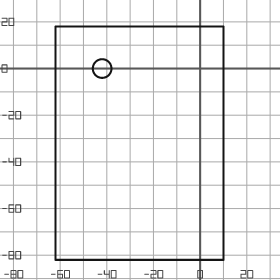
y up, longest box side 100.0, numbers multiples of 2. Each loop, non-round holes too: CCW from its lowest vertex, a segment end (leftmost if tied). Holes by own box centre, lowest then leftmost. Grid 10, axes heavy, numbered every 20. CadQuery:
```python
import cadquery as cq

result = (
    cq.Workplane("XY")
    .moveTo(-62.0, -82.0)
    .lineTo(10.0, -82.0)
    .lineTo(10.0, 18.0)
    .lineTo(-62.0, 18.0)
    .close()
    .moveTo(-42.0, 0.0)
    .circle(4.0)
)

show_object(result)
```